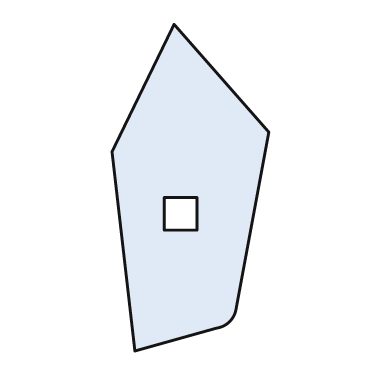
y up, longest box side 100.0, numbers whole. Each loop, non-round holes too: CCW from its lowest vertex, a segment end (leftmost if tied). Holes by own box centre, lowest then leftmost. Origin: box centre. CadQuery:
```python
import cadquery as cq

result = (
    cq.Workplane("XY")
    .moveTo(-17.0, -50.0)
    .lineTo(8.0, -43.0)
    .threePointArc((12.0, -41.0), (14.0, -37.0))
    .lineTo(24.0, 17.0)
    .lineTo(-5.0, 50.0)
    .lineTo(-24.0, 11.0)
    .close()
    .moveTo(-8.0, -13.0)
    .lineTo(2.0, -13.0)
    .lineTo(2.0, -3.0)
    .lineTo(-8.0, -3.0)
    .close()
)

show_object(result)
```